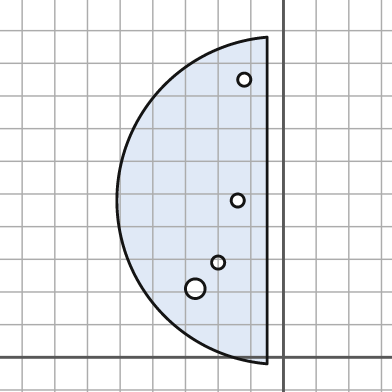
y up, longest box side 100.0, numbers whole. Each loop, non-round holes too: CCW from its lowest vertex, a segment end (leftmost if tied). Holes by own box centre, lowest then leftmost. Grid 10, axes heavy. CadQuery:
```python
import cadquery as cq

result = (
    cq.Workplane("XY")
    .moveTo(-5.0, -2.0)
    .lineTo(-5.0, 98.0)
    .threePointArc((-51.0, 48.0), (-5.0, -2.0))
    .close()
    .moveTo(-27.0, 21.0)
    .circle(3.0)
    .moveTo(-20.0, 29.0)
    .circle(2.0)
    .moveTo(-14.0, 48.0)
    .circle(2.0)
    .moveTo(-12.0, 85.0)
    .circle(2.0)
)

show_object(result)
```